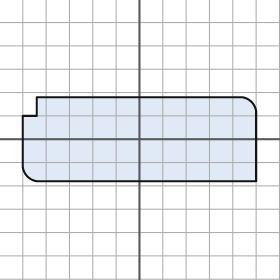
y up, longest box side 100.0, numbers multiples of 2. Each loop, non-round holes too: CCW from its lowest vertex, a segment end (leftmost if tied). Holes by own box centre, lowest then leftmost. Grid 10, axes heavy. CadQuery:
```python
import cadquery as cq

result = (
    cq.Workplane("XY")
    .moveTo(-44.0, -18.0)
    .lineTo(50.0, -18.0)
    .lineTo(50.0, 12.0)
    .threePointArc((48.0, 16.0), (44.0, 18.0))
    .lineTo(-44.0, 18.0)
    .lineTo(-44.0, 10.0)
    .lineTo(-50.0, 10.0)
    .lineTo(-50.0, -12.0)
    .threePointArc((-48.0, -16.0), (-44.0, -18.0))
    .close()
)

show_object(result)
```